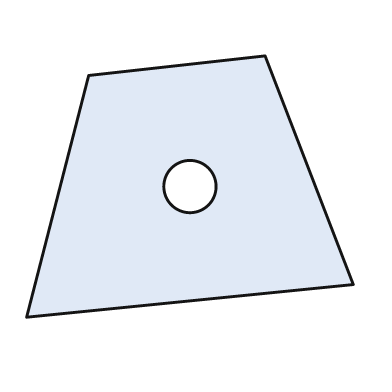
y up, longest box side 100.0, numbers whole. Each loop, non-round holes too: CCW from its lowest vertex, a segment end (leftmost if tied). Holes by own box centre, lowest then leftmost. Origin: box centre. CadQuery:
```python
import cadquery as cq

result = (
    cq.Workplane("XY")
    .moveTo(-50.0, -40.0)
    .lineTo(50.0, -30.0)
    .lineTo(23.0, 40.0)
    .lineTo(-31.0, 34.0)
    .close()
    .moveTo(0.0, 0.0)
    .circle(8.0)
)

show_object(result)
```